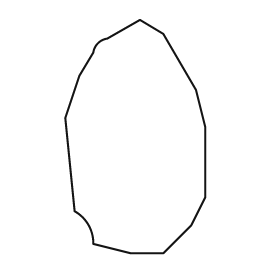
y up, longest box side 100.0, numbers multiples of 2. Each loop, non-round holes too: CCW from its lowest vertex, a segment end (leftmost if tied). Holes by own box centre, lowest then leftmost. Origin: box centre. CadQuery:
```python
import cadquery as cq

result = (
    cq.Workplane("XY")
    .moveTo(-2.0, -50.0)
    .lineTo(12.0, -50.0)
    .lineTo(24.0, -38.0)
    .lineTo(30.0, -26.0)
    .lineTo(30.0, 4.0)
    .lineTo(26.0, 20.0)
    .lineTo(12.0, 44.0)
    .lineTo(2.0, 50.0)
    .lineTo(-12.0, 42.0)
    .threePointArc((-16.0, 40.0), (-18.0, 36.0))
    .lineTo(-24.0, 26.0)
    .lineTo(-30.0, 8.0)
    .lineTo(-26.0, -32.0)
    .threePointArc((-20.0, -38.0), (-18.0, -46.0))
    .close()
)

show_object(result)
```